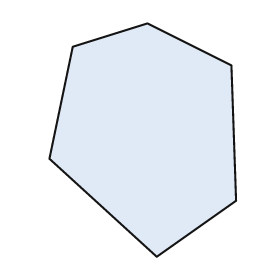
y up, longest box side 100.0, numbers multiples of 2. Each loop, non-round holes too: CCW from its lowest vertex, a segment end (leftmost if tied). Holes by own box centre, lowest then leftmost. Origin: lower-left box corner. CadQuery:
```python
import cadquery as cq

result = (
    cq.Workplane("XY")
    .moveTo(46.0, 0.0)
    .lineTo(80.0, 24.0)
    .lineTo(78.0, 82.0)
    .lineTo(42.0, 100.0)
    .lineTo(10.0, 90.0)
    .lineTo(0.0, 42.0)
    .close()
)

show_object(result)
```